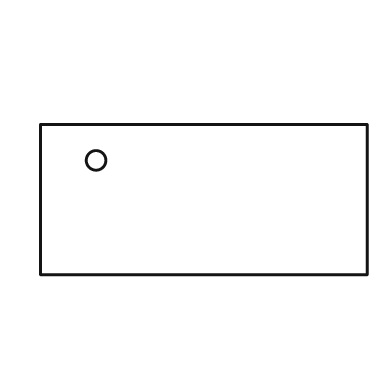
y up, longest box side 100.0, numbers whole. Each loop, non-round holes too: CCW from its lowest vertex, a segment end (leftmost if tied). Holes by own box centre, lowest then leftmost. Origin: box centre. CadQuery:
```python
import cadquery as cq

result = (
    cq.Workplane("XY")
    .moveTo(-50.0, -23.0)
    .lineTo(50.0, -23.0)
    .lineTo(50.0, 23.0)
    .lineTo(-50.0, 23.0)
    .close()
    .moveTo(-33.0, 12.0)
    .circle(3.0)
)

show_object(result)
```